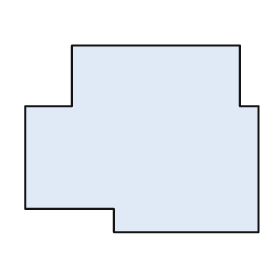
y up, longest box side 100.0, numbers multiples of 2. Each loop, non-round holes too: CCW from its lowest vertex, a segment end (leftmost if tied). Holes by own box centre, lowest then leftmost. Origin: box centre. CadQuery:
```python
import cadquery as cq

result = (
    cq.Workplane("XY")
    .moveTo(-12.0, -40.0)
    .lineTo(50.0, -40.0)
    .lineTo(50.0, 14.0)
    .lineTo(42.0, 14.0)
    .lineTo(42.0, 40.0)
    .lineTo(-30.0, 40.0)
    .lineTo(-30.0, 14.0)
    .lineTo(-50.0, 14.0)
    .lineTo(-50.0, -30.0)
    .lineTo(-12.0, -30.0)
    .close()
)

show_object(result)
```